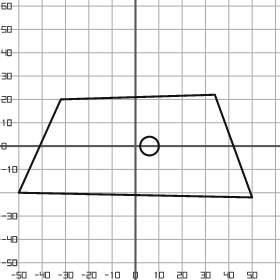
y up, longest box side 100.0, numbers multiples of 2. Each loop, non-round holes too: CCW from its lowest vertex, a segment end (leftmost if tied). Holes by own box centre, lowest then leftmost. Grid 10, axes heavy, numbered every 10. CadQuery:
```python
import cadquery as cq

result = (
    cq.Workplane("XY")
    .moveTo(50.0, -22.0)
    .lineTo(34.0, 22.0)
    .lineTo(-32.0, 20.0)
    .lineTo(-50.0, -20.0)
    .close()
    .moveTo(6.0, 0.0)
    .circle(4.0)
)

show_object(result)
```